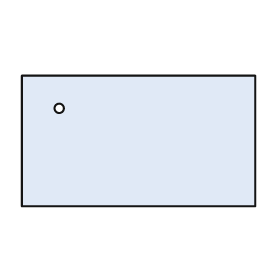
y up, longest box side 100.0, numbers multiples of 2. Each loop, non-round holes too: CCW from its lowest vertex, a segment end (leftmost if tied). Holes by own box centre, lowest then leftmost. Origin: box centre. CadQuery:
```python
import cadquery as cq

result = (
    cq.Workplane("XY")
    .moveTo(-50.0, -28.0)
    .lineTo(50.0, -28.0)
    .lineTo(50.0, 28.0)
    .lineTo(-50.0, 28.0)
    .close()
    .moveTo(-34.0, 14.0)
    .circle(2.0)
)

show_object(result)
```